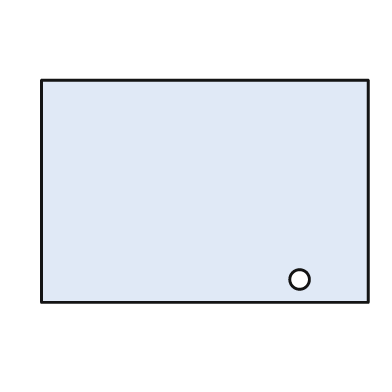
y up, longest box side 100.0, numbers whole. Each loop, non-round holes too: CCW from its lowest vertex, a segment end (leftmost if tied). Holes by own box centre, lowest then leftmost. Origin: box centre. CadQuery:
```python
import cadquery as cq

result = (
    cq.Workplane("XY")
    .moveTo(-50.0, -34.0)
    .lineTo(50.0, -34.0)
    .lineTo(50.0, 34.0)
    .lineTo(-50.0, 34.0)
    .close()
    .moveTo(29.0, -27.0)
    .circle(3.0)
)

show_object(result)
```